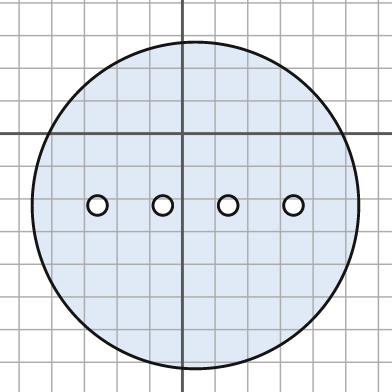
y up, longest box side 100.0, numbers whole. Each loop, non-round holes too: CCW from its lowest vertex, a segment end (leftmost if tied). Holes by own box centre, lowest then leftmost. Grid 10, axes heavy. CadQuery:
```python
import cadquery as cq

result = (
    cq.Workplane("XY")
    .moveTo(4.0, -22.0)
    .circle(50.0)
    .moveTo(-26.0, -22.0)
    .circle(3.0)
    .moveTo(-6.0, -22.0)
    .circle(3.0)
    .moveTo(14.0, -22.0)
    .circle(3.0)
    .moveTo(34.0, -22.0)
    .circle(3.0)
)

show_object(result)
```